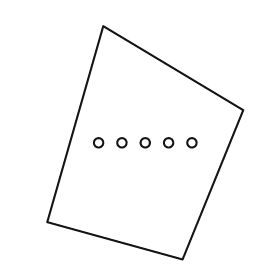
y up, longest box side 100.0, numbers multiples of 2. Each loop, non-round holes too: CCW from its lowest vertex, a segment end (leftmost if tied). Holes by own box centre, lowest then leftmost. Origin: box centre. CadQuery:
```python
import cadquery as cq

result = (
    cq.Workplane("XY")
    .moveTo(16.0, -50.0)
    .lineTo(42.0, 14.0)
    .lineTo(-18.0, 50.0)
    .lineTo(-42.0, -34.0)
    .close()
    .moveTo(-20.0, 0.0)
    .circle(2.0)
    .moveTo(-10.0, 0.0)
    .circle(2.0)
    .moveTo(0.0, 0.0)
    .circle(2.0)
    .moveTo(10.0, 0.0)
    .circle(2.0)
    .moveTo(20.0, 0.0)
    .circle(2.0)
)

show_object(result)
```